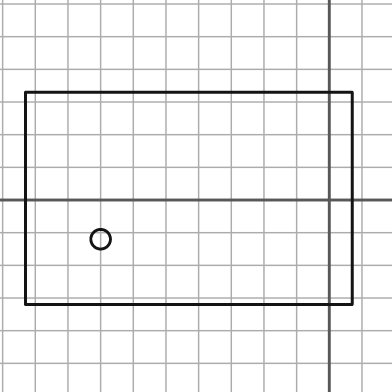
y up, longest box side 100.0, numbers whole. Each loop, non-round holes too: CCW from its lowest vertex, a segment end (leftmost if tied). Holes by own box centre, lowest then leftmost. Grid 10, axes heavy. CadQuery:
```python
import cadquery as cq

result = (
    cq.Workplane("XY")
    .moveTo(-93.0, -32.0)
    .lineTo(7.0, -32.0)
    .lineTo(7.0, 33.0)
    .lineTo(-93.0, 33.0)
    .close()
    .moveTo(-70.0, -12.0)
    .circle(3.0)
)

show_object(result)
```